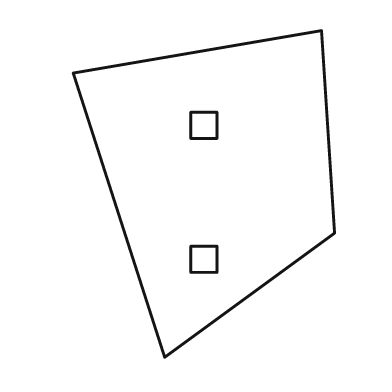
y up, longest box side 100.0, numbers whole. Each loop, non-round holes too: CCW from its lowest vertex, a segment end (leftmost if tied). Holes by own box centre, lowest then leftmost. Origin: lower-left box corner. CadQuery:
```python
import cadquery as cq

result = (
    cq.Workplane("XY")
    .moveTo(28.0, 0.0)
    .lineTo(80.0, 38.0)
    .lineTo(76.0, 100.0)
    .lineTo(0.0, 87.0)
    .close()
    .moveTo(36.0, 26.0)
    .lineTo(44.0, 26.0)
    .lineTo(44.0, 34.0)
    .lineTo(36.0, 34.0)
    .close()
    .moveTo(36.0, 67.0)
    .lineTo(44.0, 67.0)
    .lineTo(44.0, 75.0)
    .lineTo(36.0, 75.0)
    .close()
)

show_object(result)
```